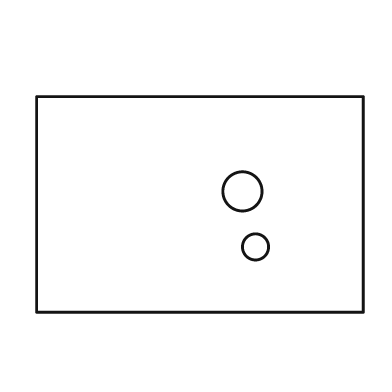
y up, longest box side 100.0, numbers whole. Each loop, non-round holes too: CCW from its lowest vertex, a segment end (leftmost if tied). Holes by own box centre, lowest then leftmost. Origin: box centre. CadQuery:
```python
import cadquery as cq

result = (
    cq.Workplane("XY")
    .moveTo(-50.0, -33.0)
    .lineTo(50.0, -33.0)
    .lineTo(50.0, 33.0)
    .lineTo(-50.0, 33.0)
    .close()
    .moveTo(17.0, -13.0)
    .circle(4.0)
    .moveTo(13.0, 4.0)
    .circle(6.0)
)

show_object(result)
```